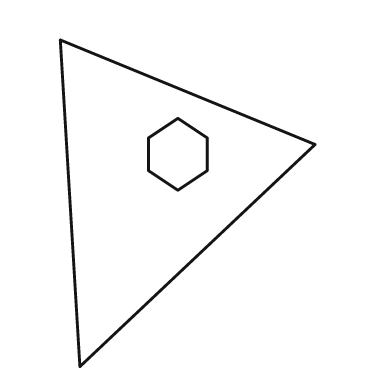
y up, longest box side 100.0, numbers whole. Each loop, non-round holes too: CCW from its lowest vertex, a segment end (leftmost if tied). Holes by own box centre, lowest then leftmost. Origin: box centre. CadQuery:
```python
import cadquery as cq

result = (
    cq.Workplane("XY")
    .moveTo(-33.0, -50.0)
    .lineTo(39.0, 18.0)
    .lineTo(-39.0, 50.0)
    .close()
    .moveTo(-3.0, 4.0)
    .lineTo(6.0, 10.0)
    .lineTo(6.0, 20.0)
    .lineTo(-3.0, 26.0)
    .lineTo(-12.0, 20.0)
    .lineTo(-12.0, 10.0)
    .close()
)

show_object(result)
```